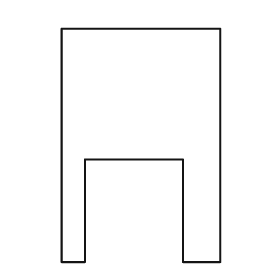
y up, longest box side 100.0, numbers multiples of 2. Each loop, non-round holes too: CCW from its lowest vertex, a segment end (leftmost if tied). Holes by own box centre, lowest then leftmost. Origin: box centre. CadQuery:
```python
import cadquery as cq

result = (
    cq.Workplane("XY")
    .moveTo(-34.0, -50.0)
    .lineTo(-24.0, -50.0)
    .lineTo(-24.0, -6.0)
    .lineTo(18.0, -6.0)
    .lineTo(18.0, -50.0)
    .lineTo(34.0, -50.0)
    .lineTo(34.0, 50.0)
    .lineTo(-34.0, 50.0)
    .close()
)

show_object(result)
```